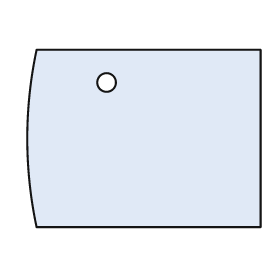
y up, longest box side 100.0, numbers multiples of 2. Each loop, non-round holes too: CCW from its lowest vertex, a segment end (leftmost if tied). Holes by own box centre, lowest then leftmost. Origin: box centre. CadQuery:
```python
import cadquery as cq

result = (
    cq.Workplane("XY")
    .moveTo(-46.0, -38.0)
    .lineTo(50.0, -38.0)
    .lineTo(50.0, 38.0)
    .lineTo(-46.0, 38.0)
    .threePointArc((-50.0, 0.0), (-46.0, -38.0))
    .close()
    .moveTo(-16.0, 24.0)
    .circle(4.0)
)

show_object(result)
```